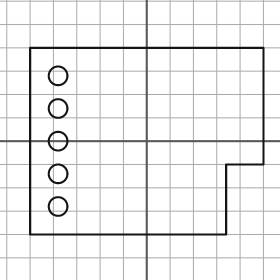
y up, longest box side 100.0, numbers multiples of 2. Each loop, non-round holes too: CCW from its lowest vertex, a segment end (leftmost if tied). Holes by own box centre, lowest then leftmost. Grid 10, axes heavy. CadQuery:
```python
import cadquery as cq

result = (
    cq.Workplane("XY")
    .moveTo(-50.0, -40.0)
    .lineTo(34.0, -40.0)
    .lineTo(34.0, -10.0)
    .lineTo(50.0, -10.0)
    .lineTo(50.0, 40.0)
    .lineTo(-50.0, 40.0)
    .close()
    .moveTo(-38.0, -28.0)
    .circle(4.0)
    .moveTo(-38.0, -14.0)
    .circle(4.0)
    .moveTo(-38.0, 0.0)
    .circle(4.0)
    .moveTo(-38.0, 14.0)
    .circle(4.0)
    .moveTo(-38.0, 28.0)
    .circle(4.0)
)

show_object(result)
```